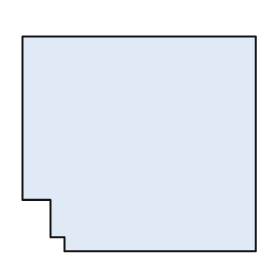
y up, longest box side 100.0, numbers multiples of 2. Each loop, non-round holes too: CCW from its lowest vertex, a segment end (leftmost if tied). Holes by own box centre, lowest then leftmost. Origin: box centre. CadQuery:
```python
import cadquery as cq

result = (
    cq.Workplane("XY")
    .moveTo(-32.0, -46.0)
    .lineTo(50.0, -46.0)
    .lineTo(50.0, 46.0)
    .lineTo(-50.0, 46.0)
    .lineTo(-50.0, -24.0)
    .lineTo(-38.0, -24.0)
    .lineTo(-38.0, -40.0)
    .lineTo(-32.0, -40.0)
    .close()
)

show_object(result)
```